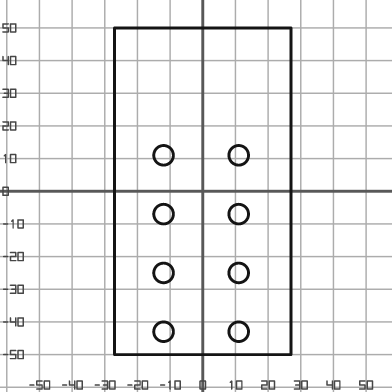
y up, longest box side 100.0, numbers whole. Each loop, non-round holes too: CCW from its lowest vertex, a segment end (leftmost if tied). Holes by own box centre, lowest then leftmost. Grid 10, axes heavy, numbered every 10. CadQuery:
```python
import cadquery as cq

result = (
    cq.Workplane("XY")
    .moveTo(-27.0, -50.0)
    .lineTo(27.0, -50.0)
    .lineTo(27.0, 50.0)
    .lineTo(-27.0, 50.0)
    .close()
    .moveTo(-12.0, -43.0)
    .circle(3.0)
    .moveTo(11.0, -43.0)
    .circle(3.0)
    .moveTo(-12.0, -25.0)
    .circle(3.0)
    .moveTo(11.0, -25.0)
    .circle(3.0)
    .moveTo(-12.0, -7.0)
    .circle(3.0)
    .moveTo(11.0, -7.0)
    .circle(3.0)
    .moveTo(-12.0, 11.0)
    .circle(3.0)
    .moveTo(11.0, 11.0)
    .circle(3.0)
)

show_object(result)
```